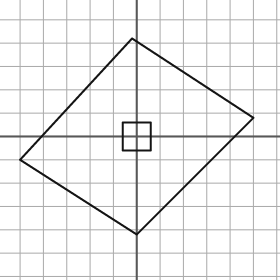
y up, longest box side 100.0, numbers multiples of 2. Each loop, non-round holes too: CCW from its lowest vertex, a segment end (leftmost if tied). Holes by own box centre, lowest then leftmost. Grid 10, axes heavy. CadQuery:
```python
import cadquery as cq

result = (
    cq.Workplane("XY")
    .moveTo(0.0, -42.0)
    .lineTo(50.0, 8.0)
    .lineTo(-2.0, 42.0)
    .lineTo(-50.0, -10.0)
    .close()
    .moveTo(-6.0, -6.0)
    .lineTo(6.0, -6.0)
    .lineTo(6.0, 6.0)
    .lineTo(-6.0, 6.0)
    .close()
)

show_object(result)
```